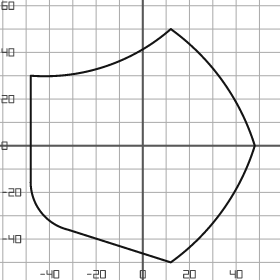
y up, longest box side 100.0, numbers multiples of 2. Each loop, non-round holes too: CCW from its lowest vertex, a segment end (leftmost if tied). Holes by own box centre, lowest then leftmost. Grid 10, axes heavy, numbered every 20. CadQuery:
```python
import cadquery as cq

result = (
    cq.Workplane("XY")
    .moveTo(12.0, -50.0)
    .threePointArc((34.0, -28.0), (48.0, 0.0))
    .threePointArc((34.0, 28.0), (12.0, 50.0))
    .threePointArc((-16.0, 34.0), (-48.0, 30.0))
    .lineTo(-48.0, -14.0)
    .threePointArc((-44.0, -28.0), (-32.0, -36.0))
    .close()
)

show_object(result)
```